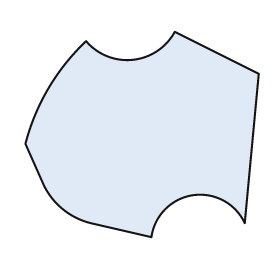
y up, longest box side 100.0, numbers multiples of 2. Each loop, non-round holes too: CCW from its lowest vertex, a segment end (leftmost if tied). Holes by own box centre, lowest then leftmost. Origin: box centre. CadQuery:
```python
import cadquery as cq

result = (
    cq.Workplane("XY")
    .moveTo(4.0, -44.0)
    .threePointArc((22.0, -26.0), (44.0, -38.0))
    .lineTo(50.0, 26.0)
    .lineTo(14.0, 44.0)
    .threePointArc((-4.0, 32.0), (-24.0, 40.0))
    .threePointArc((-40.0, 20.0), (-50.0, -4.0))
    .lineTo(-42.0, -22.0)
    .threePointArc((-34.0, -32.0), (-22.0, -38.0))
    .close()
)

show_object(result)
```